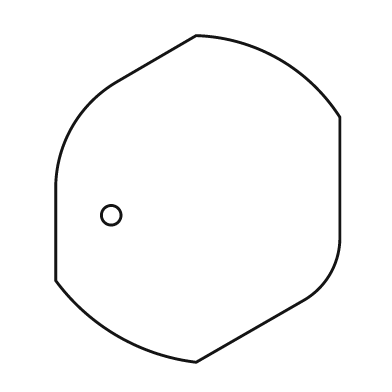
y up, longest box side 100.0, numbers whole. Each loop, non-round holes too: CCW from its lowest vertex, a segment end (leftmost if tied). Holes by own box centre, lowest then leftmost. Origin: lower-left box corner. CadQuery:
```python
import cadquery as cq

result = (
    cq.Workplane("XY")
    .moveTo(43.0, 0.0)
    .lineTo(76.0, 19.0)
    .threePointArc((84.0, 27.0), (87.0, 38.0))
    .lineTo(87.0, 75.0)
    .threePointArc((68.0, 93.0), (43.0, 100.0))
    .lineTo(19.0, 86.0)
    .threePointArc((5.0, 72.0), (0.0, 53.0))
    .lineTo(0.0, 25.0)
    .threePointArc((19.0, 8.0), (43.0, 0.0))
    .close()
    .moveTo(17.0, 45.0)
    .circle(3.0)
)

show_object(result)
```